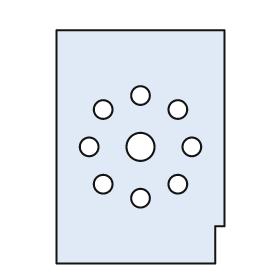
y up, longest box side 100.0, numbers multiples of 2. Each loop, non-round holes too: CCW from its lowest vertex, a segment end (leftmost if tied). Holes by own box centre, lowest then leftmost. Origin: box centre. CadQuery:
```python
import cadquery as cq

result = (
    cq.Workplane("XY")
    .moveTo(-36.0, -50.0)
    .lineTo(32.0, -50.0)
    .lineTo(32.0, -34.0)
    .lineTo(36.0, -34.0)
    .lineTo(36.0, 50.0)
    .lineTo(-36.0, 50.0)
    .close()
    .moveTo(0.0, -22.0)
    .circle(4.0)
    .moveTo(-16.0, -16.0)
    .circle(4.0)
    .moveTo(16.0, -16.0)
    .circle(4.0)
    .moveTo(-22.0, 0.0)
    .circle(4.0)
    .moveTo(0.0, 0.0)
    .circle(6.0)
    .moveTo(22.0, 0.0)
    .circle(4.0)
    .moveTo(-16.0, 16.0)
    .circle(4.0)
    .moveTo(16.0, 16.0)
    .circle(4.0)
    .moveTo(0.0, 22.0)
    .circle(4.0)
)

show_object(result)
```